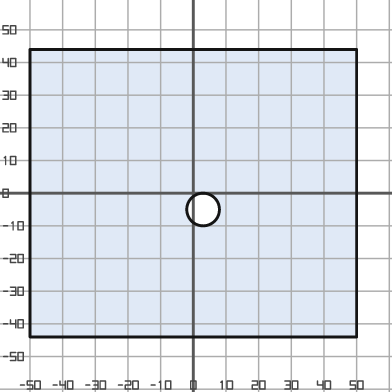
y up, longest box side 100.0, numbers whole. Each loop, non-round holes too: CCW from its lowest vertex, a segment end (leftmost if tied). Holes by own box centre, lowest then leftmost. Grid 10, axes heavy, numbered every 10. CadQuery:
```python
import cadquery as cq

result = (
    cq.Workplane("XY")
    .moveTo(-50.0, -44.0)
    .lineTo(50.0, -44.0)
    .lineTo(50.0, 44.0)
    .lineTo(-50.0, 44.0)
    .close()
    .moveTo(3.0, -5.0)
    .circle(5.0)
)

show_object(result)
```